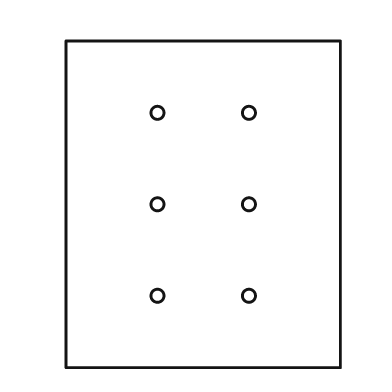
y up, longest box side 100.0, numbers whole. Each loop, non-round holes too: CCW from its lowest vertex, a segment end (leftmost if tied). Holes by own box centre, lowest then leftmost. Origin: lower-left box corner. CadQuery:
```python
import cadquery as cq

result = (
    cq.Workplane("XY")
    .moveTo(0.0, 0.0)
    .lineTo(84.0, 0.0)
    .lineTo(84.0, 100.0)
    .lineTo(0.0, 100.0)
    .close()
    .moveTo(28.0, 22.0)
    .circle(2.0)
    .moveTo(56.0, 22.0)
    .circle(2.0)
    .moveTo(28.0, 50.0)
    .circle(2.0)
    .moveTo(56.0, 50.0)
    .circle(2.0)
    .moveTo(28.0, 78.0)
    .circle(2.0)
    .moveTo(56.0, 78.0)
    .circle(2.0)
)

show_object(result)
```